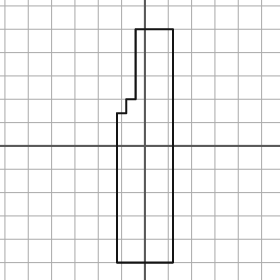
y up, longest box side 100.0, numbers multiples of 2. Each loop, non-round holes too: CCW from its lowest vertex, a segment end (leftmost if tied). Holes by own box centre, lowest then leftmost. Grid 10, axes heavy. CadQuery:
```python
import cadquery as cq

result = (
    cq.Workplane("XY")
    .moveTo(-12.0, -50.0)
    .lineTo(12.0, -50.0)
    .lineTo(12.0, 50.0)
    .lineTo(-4.0, 50.0)
    .lineTo(-4.0, 20.0)
    .lineTo(-8.0, 20.0)
    .lineTo(-8.0, 14.0)
    .lineTo(-12.0, 14.0)
    .close()
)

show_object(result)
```